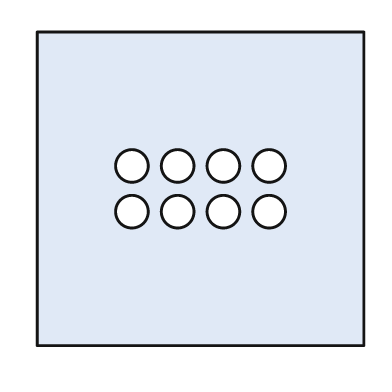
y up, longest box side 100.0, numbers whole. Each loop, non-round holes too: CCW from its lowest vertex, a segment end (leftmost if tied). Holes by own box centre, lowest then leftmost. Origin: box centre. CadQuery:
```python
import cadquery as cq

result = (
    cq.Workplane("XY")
    .moveTo(-50.0, -48.0)
    .lineTo(50.0, -48.0)
    .lineTo(50.0, 48.0)
    .lineTo(-50.0, 48.0)
    .close()
    .moveTo(-21.0, -7.0)
    .circle(5.0)
    .moveTo(-7.0, -7.0)
    .circle(5.0)
    .moveTo(7.0, -7.0)
    .circle(5.0)
    .moveTo(21.0, -7.0)
    .circle(5.0)
    .moveTo(-21.0, 7.0)
    .circle(5.0)
    .moveTo(-7.0, 7.0)
    .circle(5.0)
    .moveTo(7.0, 7.0)
    .circle(5.0)
    .moveTo(21.0, 7.0)
    .circle(5.0)
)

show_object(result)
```